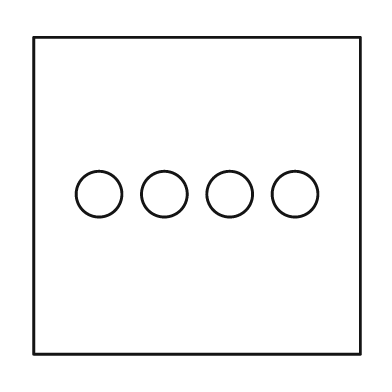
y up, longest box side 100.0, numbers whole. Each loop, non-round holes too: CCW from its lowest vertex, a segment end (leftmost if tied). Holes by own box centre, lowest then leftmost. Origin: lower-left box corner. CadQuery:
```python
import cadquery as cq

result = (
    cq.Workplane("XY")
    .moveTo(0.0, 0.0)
    .lineTo(100.0, 0.0)
    .lineTo(100.0, 97.0)
    .lineTo(0.0, 97.0)
    .close()
    .moveTo(20.0, 49.0)
    .circle(7.0)
    .moveTo(40.0, 49.0)
    .circle(7.0)
    .moveTo(60.0, 49.0)
    .circle(7.0)
    .moveTo(80.0, 49.0)
    .circle(7.0)
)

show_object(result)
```